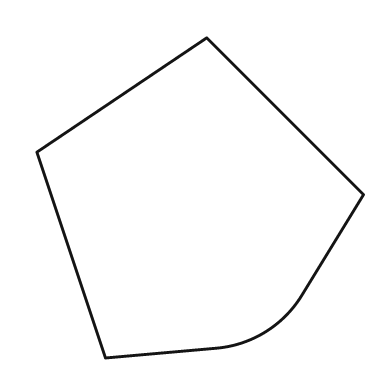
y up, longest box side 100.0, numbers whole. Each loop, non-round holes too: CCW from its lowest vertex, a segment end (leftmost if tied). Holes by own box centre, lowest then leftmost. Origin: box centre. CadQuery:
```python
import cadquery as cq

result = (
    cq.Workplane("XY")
    .moveTo(-29.0, -49.0)
    .lineTo(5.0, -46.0)
    .threePointArc((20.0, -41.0), (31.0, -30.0))
    .lineTo(50.0, 1.0)
    .lineTo(2.0, 49.0)
    .lineTo(-50.0, 14.0)
    .close()
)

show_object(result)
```